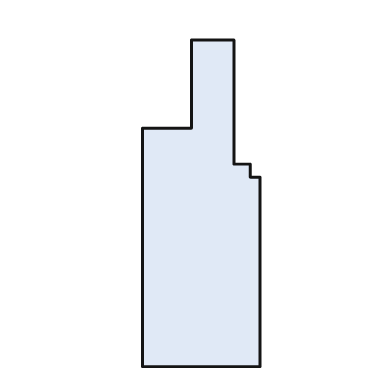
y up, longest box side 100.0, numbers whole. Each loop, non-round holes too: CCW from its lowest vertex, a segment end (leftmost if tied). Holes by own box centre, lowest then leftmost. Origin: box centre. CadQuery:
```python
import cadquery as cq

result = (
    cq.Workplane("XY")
    .moveTo(-18.0, -50.0)
    .lineTo(18.0, -50.0)
    .lineTo(18.0, 8.0)
    .lineTo(15.0, 8.0)
    .lineTo(15.0, 12.0)
    .lineTo(10.0, 12.0)
    .lineTo(10.0, 50.0)
    .lineTo(-3.0, 50.0)
    .lineTo(-3.0, 23.0)
    .lineTo(-18.0, 23.0)
    .close()
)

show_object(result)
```